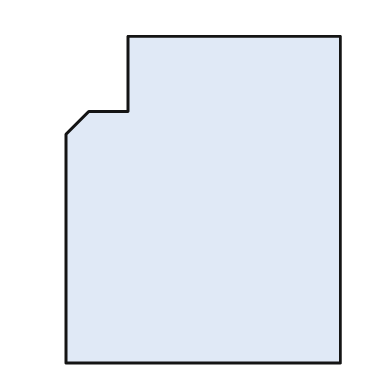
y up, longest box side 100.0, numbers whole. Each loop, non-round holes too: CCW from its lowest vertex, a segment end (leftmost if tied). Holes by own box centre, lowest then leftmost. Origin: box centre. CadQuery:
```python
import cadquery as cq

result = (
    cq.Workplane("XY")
    .moveTo(-42.0, -50.0)
    .lineTo(42.0, -50.0)
    .lineTo(42.0, 50.0)
    .lineTo(-23.0, 50.0)
    .lineTo(-23.0, 27.0)
    .lineTo(-35.0, 27.0)
    .lineTo(-42.0, 20.0)
    .close()
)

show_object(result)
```